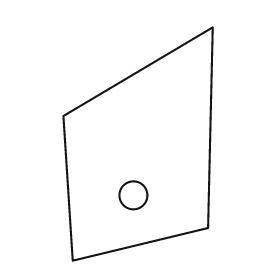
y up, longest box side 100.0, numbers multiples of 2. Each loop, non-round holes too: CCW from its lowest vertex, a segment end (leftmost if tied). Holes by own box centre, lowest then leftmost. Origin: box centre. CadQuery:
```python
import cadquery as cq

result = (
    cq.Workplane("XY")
    .moveTo(-28.0, -50.0)
    .lineTo(30.0, -36.0)
    .lineTo(32.0, 50.0)
    .lineTo(-32.0, 12.0)
    .close()
    .moveTo(-2.0, -22.0)
    .circle(6.0)
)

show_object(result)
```